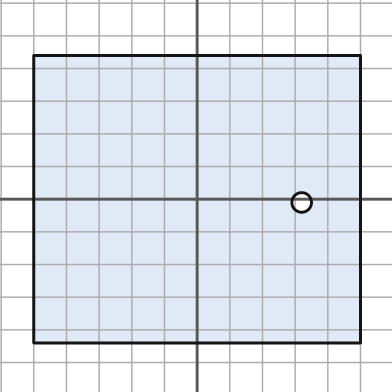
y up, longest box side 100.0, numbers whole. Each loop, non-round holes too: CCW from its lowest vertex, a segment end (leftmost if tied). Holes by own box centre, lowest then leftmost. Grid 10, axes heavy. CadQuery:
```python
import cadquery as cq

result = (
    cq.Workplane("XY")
    .moveTo(-50.0, -44.0)
    .lineTo(50.0, -44.0)
    .lineTo(50.0, 44.0)
    .lineTo(-50.0, 44.0)
    .close()
    .moveTo(32.0, -1.0)
    .circle(3.0)
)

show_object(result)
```